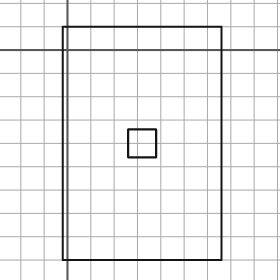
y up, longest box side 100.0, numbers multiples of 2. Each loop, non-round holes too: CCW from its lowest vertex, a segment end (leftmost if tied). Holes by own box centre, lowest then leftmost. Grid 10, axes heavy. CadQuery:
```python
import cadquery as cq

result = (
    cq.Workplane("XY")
    .moveTo(-2.0, -90.0)
    .lineTo(66.0, -90.0)
    .lineTo(66.0, 10.0)
    .lineTo(-2.0, 10.0)
    .close()
    .moveTo(26.0, -46.0)
    .lineTo(38.0, -46.0)
    .lineTo(38.0, -34.0)
    .lineTo(26.0, -34.0)
    .close()
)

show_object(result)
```